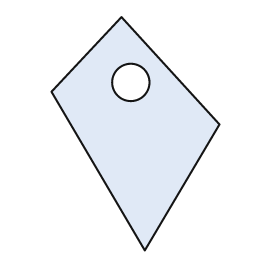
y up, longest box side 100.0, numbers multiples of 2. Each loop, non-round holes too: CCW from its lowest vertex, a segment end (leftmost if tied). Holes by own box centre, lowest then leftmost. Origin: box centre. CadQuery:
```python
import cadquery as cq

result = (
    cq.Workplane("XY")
    .moveTo(4.0, -50.0)
    .lineTo(36.0, 4.0)
    .lineTo(-6.0, 50.0)
    .lineTo(-36.0, 18.0)
    .close()
    .moveTo(-2.0, 22.0)
    .circle(8.0)
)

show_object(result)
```